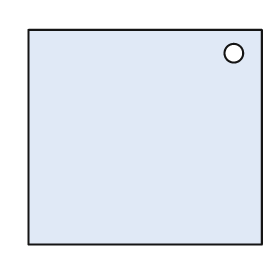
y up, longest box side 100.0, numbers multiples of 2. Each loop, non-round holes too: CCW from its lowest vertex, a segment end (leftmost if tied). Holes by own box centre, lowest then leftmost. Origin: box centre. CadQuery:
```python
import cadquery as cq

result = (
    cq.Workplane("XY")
    .moveTo(-50.0, -46.0)
    .lineTo(50.0, -46.0)
    .lineTo(50.0, 46.0)
    .lineTo(-50.0, 46.0)
    .close()
    .moveTo(38.0, 36.0)
    .circle(4.0)
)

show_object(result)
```